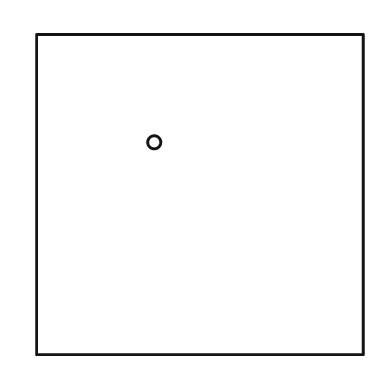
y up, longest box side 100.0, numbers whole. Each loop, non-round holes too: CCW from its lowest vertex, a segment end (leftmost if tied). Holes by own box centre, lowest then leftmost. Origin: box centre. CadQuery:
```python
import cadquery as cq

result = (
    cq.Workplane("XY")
    .moveTo(-50.0, -49.0)
    .lineTo(50.0, -49.0)
    .lineTo(50.0, 49.0)
    .lineTo(-50.0, 49.0)
    .close()
    .moveTo(-14.0, 16.0)
    .circle(2.0)
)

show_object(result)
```